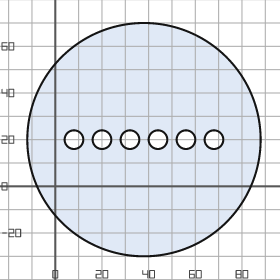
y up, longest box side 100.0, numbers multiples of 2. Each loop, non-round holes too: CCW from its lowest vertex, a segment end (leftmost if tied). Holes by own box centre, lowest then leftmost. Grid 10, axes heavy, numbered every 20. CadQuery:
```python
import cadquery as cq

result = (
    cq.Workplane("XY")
    .moveTo(38.0, 20.0)
    .circle(50.0)
    .moveTo(8.0, 20.0)
    .circle(4.0)
    .moveTo(20.0, 20.0)
    .circle(4.0)
    .moveTo(32.0, 20.0)
    .circle(4.0)
    .moveTo(44.0, 20.0)
    .circle(4.0)
    .moveTo(56.0, 20.0)
    .circle(4.0)
    .moveTo(68.0, 20.0)
    .circle(4.0)
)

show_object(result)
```